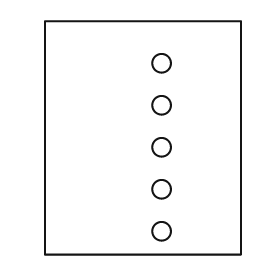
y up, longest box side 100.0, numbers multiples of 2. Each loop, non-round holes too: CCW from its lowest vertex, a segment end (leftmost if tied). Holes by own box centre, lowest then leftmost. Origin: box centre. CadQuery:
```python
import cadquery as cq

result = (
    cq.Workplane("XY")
    .moveTo(-42.0, -50.0)
    .lineTo(42.0, -50.0)
    .lineTo(42.0, 50.0)
    .lineTo(-42.0, 50.0)
    .close()
    .moveTo(8.0, -40.0)
    .circle(4.0)
    .moveTo(8.0, -22.0)
    .circle(4.0)
    .moveTo(8.0, -4.0)
    .circle(4.0)
    .moveTo(8.0, 14.0)
    .circle(4.0)
    .moveTo(8.0, 32.0)
    .circle(4.0)
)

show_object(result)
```